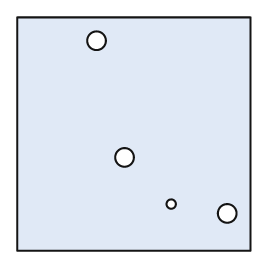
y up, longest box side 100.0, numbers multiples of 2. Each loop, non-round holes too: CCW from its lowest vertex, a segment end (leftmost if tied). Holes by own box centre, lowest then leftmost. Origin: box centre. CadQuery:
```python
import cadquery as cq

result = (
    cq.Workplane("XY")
    .moveTo(-50.0, -50.0)
    .lineTo(50.0, -50.0)
    .lineTo(50.0, 50.0)
    .lineTo(-50.0, 50.0)
    .close()
    .moveTo(40.0, -34.0)
    .circle(4.0)
    .moveTo(16.0, -30.0)
    .circle(2.0)
    .moveTo(-4.0, -10.0)
    .circle(4.0)
    .moveTo(-16.0, 40.0)
    .circle(4.0)
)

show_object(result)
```